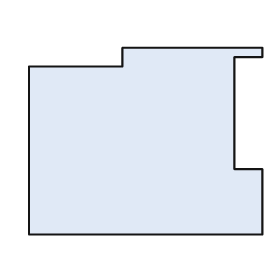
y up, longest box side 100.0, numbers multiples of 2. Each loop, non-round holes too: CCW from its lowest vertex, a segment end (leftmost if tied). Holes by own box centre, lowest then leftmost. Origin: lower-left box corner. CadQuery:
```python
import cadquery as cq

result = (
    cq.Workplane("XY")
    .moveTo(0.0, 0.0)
    .lineTo(100.0, 0.0)
    .lineTo(100.0, 28.0)
    .lineTo(88.0, 28.0)
    .lineTo(88.0, 76.0)
    .lineTo(100.0, 76.0)
    .lineTo(100.0, 80.0)
    .lineTo(40.0, 80.0)
    .lineTo(40.0, 72.0)
    .lineTo(0.0, 72.0)
    .close()
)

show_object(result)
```